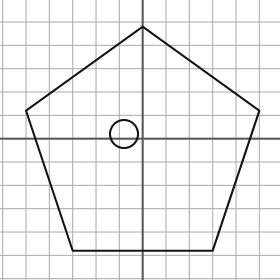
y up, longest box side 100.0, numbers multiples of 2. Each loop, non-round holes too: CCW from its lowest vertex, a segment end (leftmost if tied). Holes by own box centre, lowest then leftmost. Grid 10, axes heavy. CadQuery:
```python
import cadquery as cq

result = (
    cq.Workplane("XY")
    .moveTo(-30.0, -48.0)
    .lineTo(30.0, -48.0)
    .lineTo(50.0, 12.0)
    .lineTo(0.0, 48.0)
    .lineTo(-50.0, 12.0)
    .close()
    .moveTo(-8.0, 2.0)
    .circle(6.0)
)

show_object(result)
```